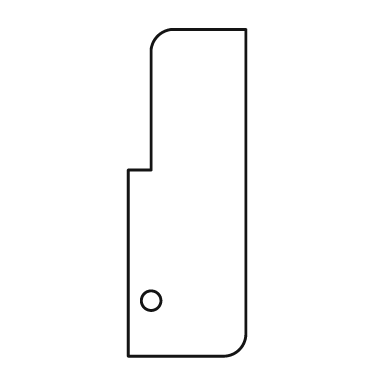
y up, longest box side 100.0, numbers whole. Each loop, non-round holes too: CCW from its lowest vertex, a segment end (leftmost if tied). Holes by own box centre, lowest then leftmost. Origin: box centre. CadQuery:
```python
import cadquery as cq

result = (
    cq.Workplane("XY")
    .moveTo(-18.0, -50.0)
    .lineTo(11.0, -50.0)
    .threePointArc((16.0, -48.0), (18.0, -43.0))
    .lineTo(18.0, 50.0)
    .lineTo(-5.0, 50.0)
    .threePointArc((-9.0, 48.0), (-11.0, 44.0))
    .lineTo(-11.0, 7.0)
    .lineTo(-18.0, 7.0)
    .close()
    .moveTo(-11.0, -33.0)
    .circle(3.0)
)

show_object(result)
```